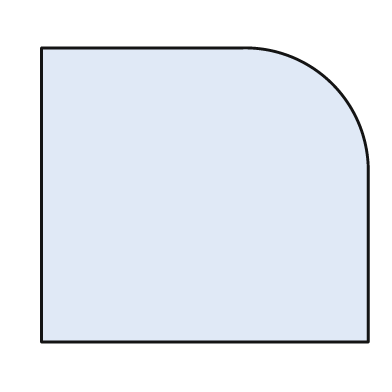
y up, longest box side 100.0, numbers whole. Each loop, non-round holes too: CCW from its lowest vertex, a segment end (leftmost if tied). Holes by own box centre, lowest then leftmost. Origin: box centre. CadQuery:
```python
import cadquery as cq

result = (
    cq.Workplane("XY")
    .moveTo(-50.0, -45.0)
    .lineTo(50.0, -45.0)
    .lineTo(50.0, 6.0)
    .threePointArc((39.0, 34.0), (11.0, 45.0))
    .lineTo(-50.0, 45.0)
    .close()
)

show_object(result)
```